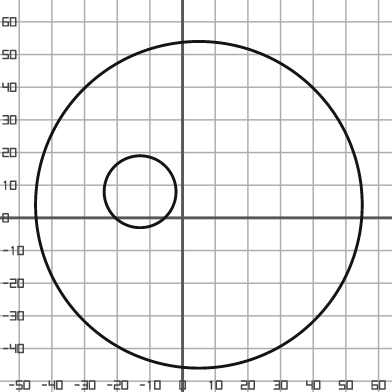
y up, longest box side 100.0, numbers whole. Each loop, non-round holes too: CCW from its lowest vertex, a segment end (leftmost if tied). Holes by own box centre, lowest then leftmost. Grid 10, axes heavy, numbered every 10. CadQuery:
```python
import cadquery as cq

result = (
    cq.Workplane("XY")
    .moveTo(5.0, 4.0)
    .circle(50.0)
    .moveTo(-13.0, 8.0)
    .circle(11.0)
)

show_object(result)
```